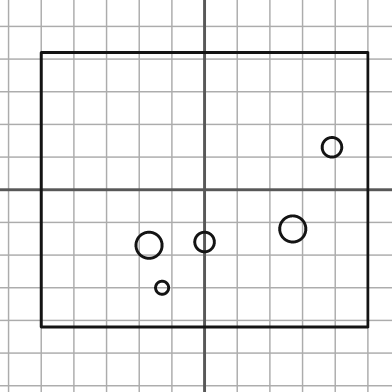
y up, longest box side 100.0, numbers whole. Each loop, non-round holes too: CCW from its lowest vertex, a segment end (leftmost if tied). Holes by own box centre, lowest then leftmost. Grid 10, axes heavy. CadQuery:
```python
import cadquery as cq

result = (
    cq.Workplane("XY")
    .moveTo(-50.0, -42.0)
    .lineTo(50.0, -42.0)
    .lineTo(50.0, 42.0)
    .lineTo(-50.0, 42.0)
    .close()
    .moveTo(-13.0, -30.0)
    .circle(2.0)
    .moveTo(-17.0, -17.0)
    .circle(4.0)
    .moveTo(0.0, -16.0)
    .circle(3.0)
    .moveTo(27.0, -12.0)
    .circle(4.0)
    .moveTo(39.0, 13.0)
    .circle(3.0)
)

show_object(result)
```